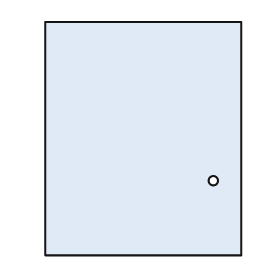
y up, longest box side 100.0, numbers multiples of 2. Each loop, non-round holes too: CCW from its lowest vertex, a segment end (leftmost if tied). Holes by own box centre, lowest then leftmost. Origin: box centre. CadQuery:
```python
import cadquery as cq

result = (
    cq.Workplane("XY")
    .moveTo(-42.0, -50.0)
    .lineTo(42.0, -50.0)
    .lineTo(42.0, 50.0)
    .lineTo(-42.0, 50.0)
    .close()
    .moveTo(30.0, -18.0)
    .circle(2.0)
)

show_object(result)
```